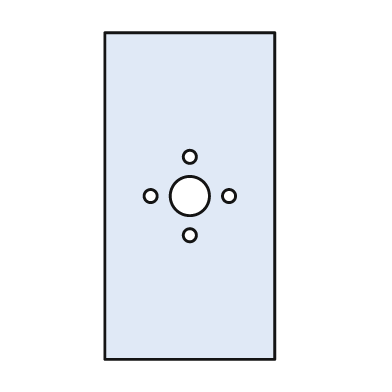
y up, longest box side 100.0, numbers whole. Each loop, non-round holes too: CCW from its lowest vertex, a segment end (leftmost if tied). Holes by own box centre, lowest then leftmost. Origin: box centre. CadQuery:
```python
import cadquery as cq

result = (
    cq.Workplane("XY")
    .moveTo(-26.0, -50.0)
    .lineTo(26.0, -50.0)
    .lineTo(26.0, 50.0)
    .lineTo(-26.0, 50.0)
    .close()
    .moveTo(0.0, -12.0)
    .circle(2.0)
    .moveTo(-12.0, 0.0)
    .circle(2.0)
    .moveTo(0.0, 0.0)
    .circle(6.0)
    .moveTo(12.0, 0.0)
    .circle(2.0)
    .moveTo(0.0, 12.0)
    .circle(2.0)
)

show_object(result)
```